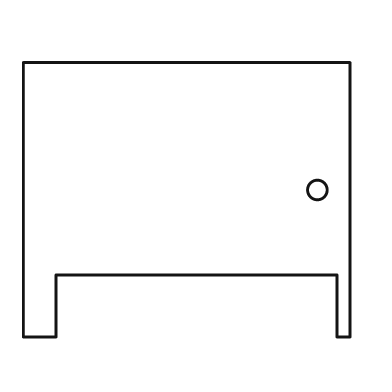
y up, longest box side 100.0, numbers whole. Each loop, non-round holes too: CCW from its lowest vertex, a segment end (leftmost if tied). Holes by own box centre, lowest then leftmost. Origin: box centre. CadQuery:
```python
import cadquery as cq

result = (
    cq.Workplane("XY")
    .moveTo(-50.0, -42.0)
    .lineTo(-40.0, -42.0)
    .lineTo(-40.0, -23.0)
    .lineTo(46.0, -23.0)
    .lineTo(46.0, -42.0)
    .lineTo(50.0, -42.0)
    .lineTo(50.0, 42.0)
    .lineTo(-50.0, 42.0)
    .close()
    .moveTo(40.0, 3.0)
    .circle(3.0)
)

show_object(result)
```